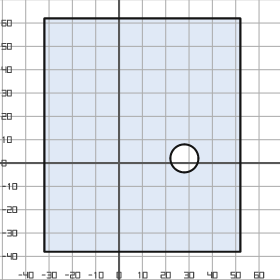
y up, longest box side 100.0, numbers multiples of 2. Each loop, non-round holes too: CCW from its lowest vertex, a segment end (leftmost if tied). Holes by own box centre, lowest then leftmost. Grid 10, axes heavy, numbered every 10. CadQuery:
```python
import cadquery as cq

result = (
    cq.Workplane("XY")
    .moveTo(-32.0, -38.0)
    .lineTo(52.0, -38.0)
    .lineTo(52.0, 62.0)
    .lineTo(-32.0, 62.0)
    .close()
    .moveTo(28.0, 2.0)
    .circle(6.0)
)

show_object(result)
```